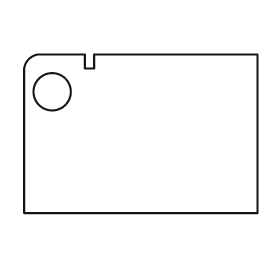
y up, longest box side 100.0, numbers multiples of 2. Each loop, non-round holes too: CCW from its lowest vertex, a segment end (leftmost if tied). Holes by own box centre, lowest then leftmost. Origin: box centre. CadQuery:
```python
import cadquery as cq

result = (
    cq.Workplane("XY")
    .moveTo(-50.0, -34.0)
    .lineTo(50.0, -34.0)
    .lineTo(50.0, 34.0)
    .lineTo(-20.0, 34.0)
    .lineTo(-20.0, 28.0)
    .lineTo(-24.0, 28.0)
    .lineTo(-24.0, 34.0)
    .lineTo(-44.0, 34.0)
    .threePointArc((-48.0, 32.0), (-50.0, 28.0))
    .close()
    .moveTo(-38.0, 18.0)
    .circle(8.0)
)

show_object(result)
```